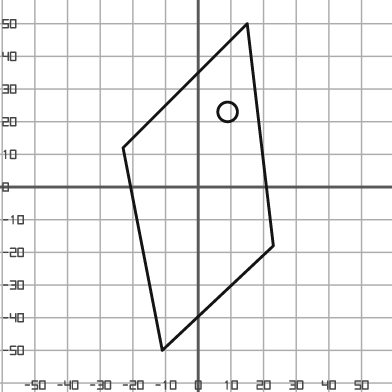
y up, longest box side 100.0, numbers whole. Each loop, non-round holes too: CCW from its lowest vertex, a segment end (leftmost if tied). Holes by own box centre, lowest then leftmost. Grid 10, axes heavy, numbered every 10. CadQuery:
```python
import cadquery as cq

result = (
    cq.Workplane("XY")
    .moveTo(-11.0, -50.0)
    .lineTo(23.0, -18.0)
    .lineTo(15.0, 50.0)
    .lineTo(-23.0, 12.0)
    .close()
    .moveTo(9.0, 23.0)
    .circle(3.0)
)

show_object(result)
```